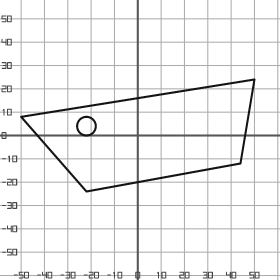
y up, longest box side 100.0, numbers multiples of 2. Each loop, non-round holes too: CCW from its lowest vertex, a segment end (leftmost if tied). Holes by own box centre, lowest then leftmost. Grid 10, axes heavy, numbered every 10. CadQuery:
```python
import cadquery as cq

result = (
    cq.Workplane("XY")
    .moveTo(-22.0, -24.0)
    .lineTo(44.0, -12.0)
    .lineTo(50.0, 24.0)
    .lineTo(-50.0, 8.0)
    .close()
    .moveTo(-22.0, 4.0)
    .circle(4.0)
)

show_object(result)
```